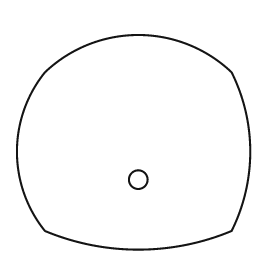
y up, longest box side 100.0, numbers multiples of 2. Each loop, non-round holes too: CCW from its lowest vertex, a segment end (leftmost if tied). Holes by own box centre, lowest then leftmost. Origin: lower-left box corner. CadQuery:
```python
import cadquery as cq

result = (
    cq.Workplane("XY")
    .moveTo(12.0, 8.0)
    .threePointArc((52.0, 0.0), (92.0, 8.0))
    .threePointArc((100.0, 42.0), (92.0, 76.0))
    .threePointArc((52.0, 92.0), (12.0, 76.0))
    .threePointArc((0.0, 42.0), (12.0, 8.0))
    .close()
    .moveTo(52.0, 30.0)
    .circle(4.0)
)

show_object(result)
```